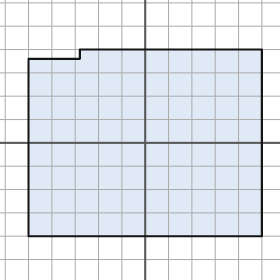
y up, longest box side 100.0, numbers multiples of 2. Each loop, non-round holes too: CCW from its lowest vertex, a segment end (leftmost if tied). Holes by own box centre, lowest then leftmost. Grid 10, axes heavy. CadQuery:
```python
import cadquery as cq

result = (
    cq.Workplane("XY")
    .moveTo(-50.0, -40.0)
    .lineTo(50.0, -40.0)
    .lineTo(50.0, 40.0)
    .lineTo(-28.0, 40.0)
    .lineTo(-28.0, 36.0)
    .lineTo(-50.0, 36.0)
    .close()
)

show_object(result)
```